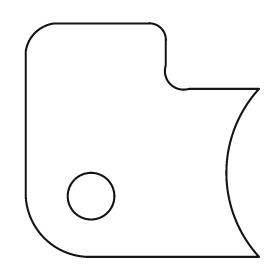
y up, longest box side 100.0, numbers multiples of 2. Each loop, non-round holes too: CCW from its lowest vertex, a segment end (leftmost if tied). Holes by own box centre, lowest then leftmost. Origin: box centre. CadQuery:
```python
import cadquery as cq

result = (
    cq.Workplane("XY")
    .moveTo(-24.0, -50.0)
    .lineTo(50.0, -50.0)
    .threePointArc((36.0, -14.0), (50.0, 22.0))
    .lineTo(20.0, 22.0)
    .threePointArc((12.0, 24.0), (10.0, 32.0))
    .lineTo(10.0, 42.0)
    .threePointArc((8.0, 48.0), (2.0, 50.0))
    .lineTo(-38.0, 50.0)
    .threePointArc((-46.0, 46.0), (-50.0, 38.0))
    .lineTo(-50.0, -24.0)
    .threePointArc((-42.0, -42.0), (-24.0, -50.0))
    .close()
    .moveTo(-22.0, -24.0)
    .circle(10.0)
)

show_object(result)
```